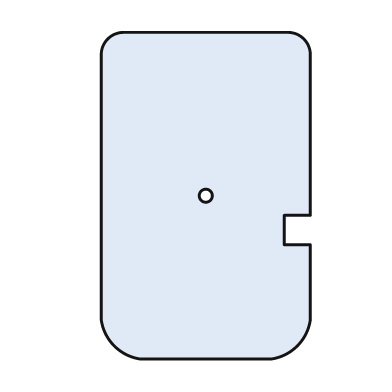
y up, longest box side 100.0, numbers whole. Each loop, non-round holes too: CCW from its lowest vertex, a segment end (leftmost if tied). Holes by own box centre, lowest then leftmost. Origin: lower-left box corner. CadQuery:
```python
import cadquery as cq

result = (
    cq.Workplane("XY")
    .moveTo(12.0, 0.0)
    .lineTo(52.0, 0.0)
    .threePointArc((60.0, 4.0), (64.0, 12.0))
    .lineTo(64.0, 35.0)
    .lineTo(56.0, 35.0)
    .lineTo(56.0, 44.0)
    .lineTo(64.0, 44.0)
    .lineTo(64.0, 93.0)
    .threePointArc((62.0, 98.0), (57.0, 100.0))
    .lineTo(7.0, 100.0)
    .threePointArc((2.0, 98.0), (0.0, 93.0))
    .lineTo(0.0, 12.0)
    .threePointArc((4.0, 4.0), (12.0, 0.0))
    .close()
    .moveTo(32.0, 50.0)
    .circle(2.0)
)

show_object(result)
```